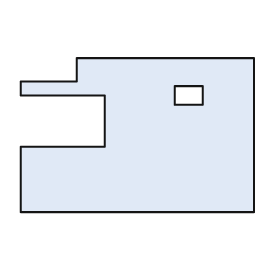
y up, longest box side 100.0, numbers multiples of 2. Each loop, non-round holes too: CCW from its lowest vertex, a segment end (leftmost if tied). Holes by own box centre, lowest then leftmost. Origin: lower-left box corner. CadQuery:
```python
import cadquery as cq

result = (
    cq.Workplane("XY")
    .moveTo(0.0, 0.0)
    .lineTo(100.0, 0.0)
    .lineTo(100.0, 66.0)
    .lineTo(24.0, 66.0)
    .lineTo(24.0, 56.0)
    .lineTo(0.0, 56.0)
    .lineTo(0.0, 50.0)
    .lineTo(36.0, 50.0)
    .lineTo(36.0, 28.0)
    .lineTo(0.0, 28.0)
    .close()
    .moveTo(66.0, 46.0)
    .lineTo(78.0, 46.0)
    .lineTo(78.0, 54.0)
    .lineTo(66.0, 54.0)
    .close()
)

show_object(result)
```